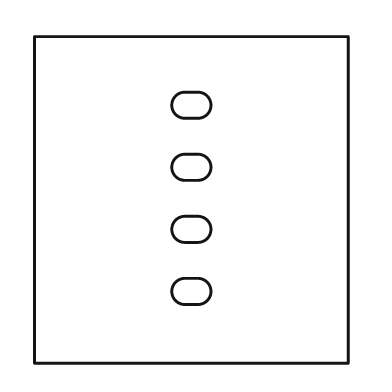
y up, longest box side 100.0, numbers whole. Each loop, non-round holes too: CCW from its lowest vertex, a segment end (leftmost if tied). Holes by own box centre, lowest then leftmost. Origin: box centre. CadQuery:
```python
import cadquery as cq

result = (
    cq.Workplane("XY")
    .moveTo(-48.0, -50.0)
    .lineTo(48.0, -50.0)
    .lineTo(48.0, 50.0)
    .lineTo(-48.0, 50.0)
    .close()
    .moveTo(-2.0, -32.0)
    .lineTo(2.0, -32.0)
    .threePointArc((6.0, -28.0), (2.0, -24.0))
    .lineTo(-2.0, -24.0)
    .threePointArc((-6.0, -28.0), (-2.0, -32.0))
    .close()
    .moveTo(-2.0, -13.0)
    .lineTo(2.0, -13.0)
    .threePointArc((6.0, -9.0), (2.0, -5.0))
    .lineTo(-2.0, -5.0)
    .threePointArc((-6.0, -9.0), (-2.0, -13.0))
    .close()
    .moveTo(-2.0, 6.0)
    .lineTo(2.0, 6.0)
    .threePointArc((6.0, 10.0), (2.0, 14.0))
    .lineTo(-2.0, 14.0)
    .threePointArc((-6.0, 10.0), (-2.0, 6.0))
    .close()
    .moveTo(-2.0, 25.0)
    .lineTo(2.0, 25.0)
    .threePointArc((6.0, 29.0), (2.0, 33.0))
    .lineTo(-2.0, 33.0)
    .threePointArc((-6.0, 29.0), (-2.0, 25.0))
    .close()
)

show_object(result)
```